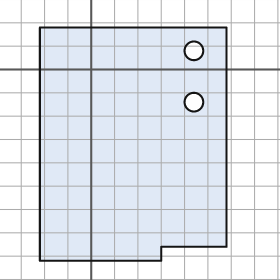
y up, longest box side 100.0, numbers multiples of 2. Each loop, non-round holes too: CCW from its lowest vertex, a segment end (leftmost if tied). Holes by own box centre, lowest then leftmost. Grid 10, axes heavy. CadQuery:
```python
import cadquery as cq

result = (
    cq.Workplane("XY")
    .moveTo(-22.0, -82.0)
    .lineTo(30.0, -82.0)
    .lineTo(30.0, -76.0)
    .lineTo(58.0, -76.0)
    .lineTo(58.0, 18.0)
    .lineTo(-22.0, 18.0)
    .close()
    .moveTo(44.0, -14.0)
    .circle(4.0)
    .moveTo(44.0, 8.0)
    .circle(4.0)
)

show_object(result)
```